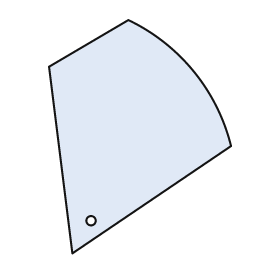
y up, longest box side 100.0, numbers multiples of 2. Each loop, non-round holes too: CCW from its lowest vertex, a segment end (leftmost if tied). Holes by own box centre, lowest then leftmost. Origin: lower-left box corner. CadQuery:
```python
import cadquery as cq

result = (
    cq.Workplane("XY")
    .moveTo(10.0, 0.0)
    .lineTo(78.0, 46.0)
    .threePointArc((62.0, 78.0), (34.0, 100.0))
    .lineTo(0.0, 80.0)
    .close()
    .moveTo(18.0, 14.0)
    .circle(2.0)
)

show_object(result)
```